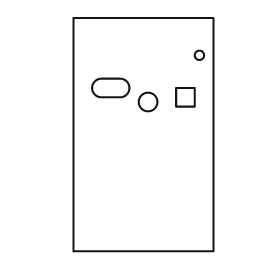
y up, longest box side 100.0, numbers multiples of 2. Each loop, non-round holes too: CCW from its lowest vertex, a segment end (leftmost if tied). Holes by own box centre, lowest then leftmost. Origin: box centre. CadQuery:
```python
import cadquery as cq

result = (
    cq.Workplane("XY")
    .moveTo(-30.0, -50.0)
    .lineTo(30.0, -50.0)
    .lineTo(30.0, 50.0)
    .lineTo(-30.0, 50.0)
    .close()
    .moveTo(2.0, 14.0)
    .circle(4.0)
    .moveTo(14.0, 12.0)
    .lineTo(22.0, 12.0)
    .lineTo(22.0, 20.0)
    .lineTo(14.0, 20.0)
    .close()
    .moveTo(-18.0, 16.0)
    .lineTo(-10.0, 16.0)
    .threePointArc((-6.0, 20.0), (-10.0, 24.0))
    .lineTo(-18.0, 24.0)
    .threePointArc((-22.0, 20.0), (-18.0, 16.0))
    .close()
    .moveTo(24.0, 34.0)
    .circle(2.0)
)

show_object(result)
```